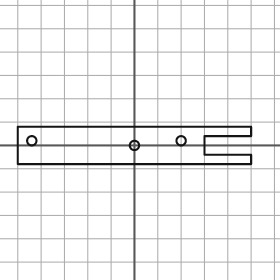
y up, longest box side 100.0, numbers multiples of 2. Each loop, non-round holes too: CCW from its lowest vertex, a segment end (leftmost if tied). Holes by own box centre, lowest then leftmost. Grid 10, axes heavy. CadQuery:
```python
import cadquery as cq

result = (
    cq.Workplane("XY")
    .moveTo(-50.0, -8.0)
    .lineTo(50.0, -8.0)
    .lineTo(50.0, -4.0)
    .lineTo(30.0, -4.0)
    .lineTo(30.0, 4.0)
    .lineTo(50.0, 4.0)
    .lineTo(50.0, 8.0)
    .lineTo(-50.0, 8.0)
    .close()
    .moveTo(0.0, 0.0)
    .circle(2.0)
    .moveTo(-44.0, 2.0)
    .circle(2.0)
    .moveTo(20.0, 2.0)
    .circle(2.0)
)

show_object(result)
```